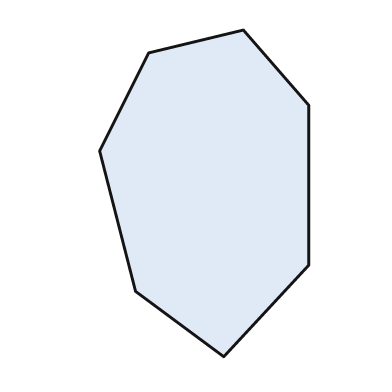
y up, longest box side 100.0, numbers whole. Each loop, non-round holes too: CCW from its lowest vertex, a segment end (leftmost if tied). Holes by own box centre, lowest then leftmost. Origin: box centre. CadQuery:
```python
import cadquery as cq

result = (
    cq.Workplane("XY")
    .moveTo(6.0, -50.0)
    .lineTo(32.0, -22.0)
    .lineTo(32.0, 27.0)
    .lineTo(12.0, 50.0)
    .lineTo(-17.0, 43.0)
    .lineTo(-32.0, 13.0)
    .lineTo(-21.0, -30.0)
    .close()
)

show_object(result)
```